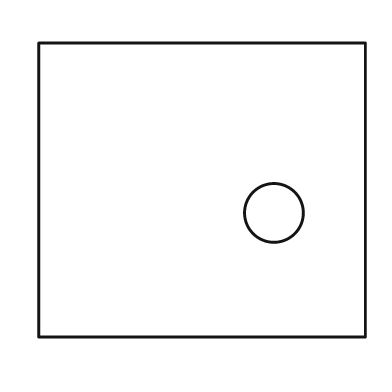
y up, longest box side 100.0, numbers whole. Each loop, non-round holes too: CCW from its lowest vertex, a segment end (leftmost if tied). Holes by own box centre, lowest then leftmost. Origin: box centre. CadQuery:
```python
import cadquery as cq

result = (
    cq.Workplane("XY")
    .moveTo(-50.0, -45.0)
    .lineTo(50.0, -45.0)
    .lineTo(50.0, 45.0)
    .lineTo(-50.0, 45.0)
    .close()
    .moveTo(22.0, -7.0)
    .circle(9.0)
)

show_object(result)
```